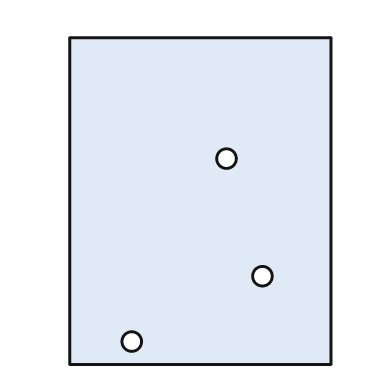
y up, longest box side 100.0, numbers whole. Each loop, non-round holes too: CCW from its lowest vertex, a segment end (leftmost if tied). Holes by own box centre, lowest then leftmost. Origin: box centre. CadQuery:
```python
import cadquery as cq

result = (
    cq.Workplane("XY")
    .moveTo(-40.0, -50.0)
    .lineTo(40.0, -50.0)
    .lineTo(40.0, 50.0)
    .lineTo(-40.0, 50.0)
    .close()
    .moveTo(-21.0, -43.0)
    .circle(3.0)
    .moveTo(19.0, -23.0)
    .circle(3.0)
    .moveTo(8.0, 13.0)
    .circle(3.0)
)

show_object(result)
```